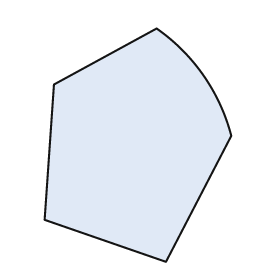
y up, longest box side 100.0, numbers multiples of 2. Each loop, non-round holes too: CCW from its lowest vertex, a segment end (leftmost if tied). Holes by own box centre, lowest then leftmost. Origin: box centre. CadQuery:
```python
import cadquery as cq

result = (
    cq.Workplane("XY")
    .moveTo(12.0, -50.0)
    .lineTo(40.0, 4.0)
    .threePointArc((28.0, 30.0), (8.0, 50.0))
    .lineTo(-36.0, 26.0)
    .lineTo(-40.0, -32.0)
    .close()
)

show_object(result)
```